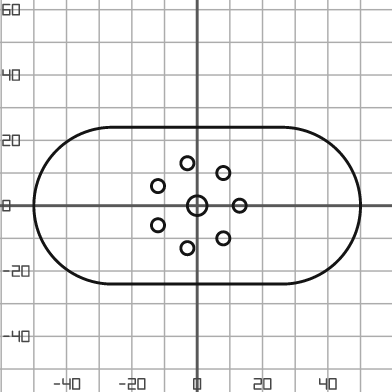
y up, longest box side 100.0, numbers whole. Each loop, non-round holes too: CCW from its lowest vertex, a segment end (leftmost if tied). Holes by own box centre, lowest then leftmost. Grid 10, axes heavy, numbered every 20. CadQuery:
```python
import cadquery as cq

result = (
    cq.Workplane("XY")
    .moveTo(-26.0, -24.0)
    .lineTo(26.0, -24.0)
    .threePointArc((50.0, 0.0), (26.0, 24.0))
    .lineTo(-26.0, 24.0)
    .threePointArc((-50.0, 0.0), (-26.0, -24.0))
    .close()
    .moveTo(-3.0, -13.0)
    .circle(2.0)
    .moveTo(8.0, -10.0)
    .circle(2.0)
    .moveTo(-12.0, -6.0)
    .circle(2.0)
    .moveTo(0.0, 0.0)
    .circle(3.0)
    .moveTo(13.0, 0.0)
    .circle(2.0)
    .moveTo(-12.0, 6.0)
    .circle(2.0)
    .moveTo(8.0, 10.0)
    .circle(2.0)
    .moveTo(-3.0, 13.0)
    .circle(2.0)
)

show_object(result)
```